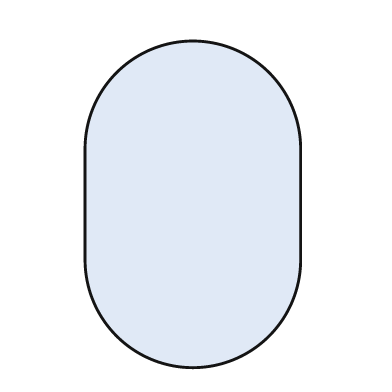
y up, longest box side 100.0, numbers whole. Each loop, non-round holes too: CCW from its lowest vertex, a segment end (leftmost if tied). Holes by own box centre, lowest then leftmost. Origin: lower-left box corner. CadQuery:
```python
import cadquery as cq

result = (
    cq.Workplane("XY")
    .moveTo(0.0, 33.0)
    .threePointArc((33.0, 0.0), (66.0, 33.0))
    .lineTo(66.0, 67.0)
    .threePointArc((33.0, 100.0), (0.0, 67.0))
    .close()
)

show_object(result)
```